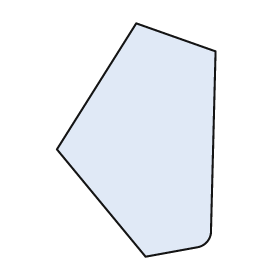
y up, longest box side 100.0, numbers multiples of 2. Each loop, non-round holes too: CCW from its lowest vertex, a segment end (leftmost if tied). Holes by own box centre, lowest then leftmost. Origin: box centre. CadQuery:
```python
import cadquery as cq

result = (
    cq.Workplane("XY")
    .moveTo(4.0, -50.0)
    .lineTo(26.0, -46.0)
    .threePointArc((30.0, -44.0), (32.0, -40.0))
    .lineTo(34.0, 38.0)
    .lineTo(0.0, 50.0)
    .lineTo(-34.0, -4.0)
    .close()
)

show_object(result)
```